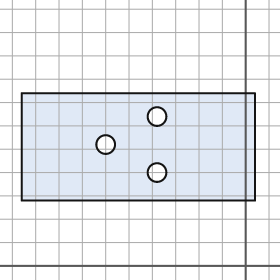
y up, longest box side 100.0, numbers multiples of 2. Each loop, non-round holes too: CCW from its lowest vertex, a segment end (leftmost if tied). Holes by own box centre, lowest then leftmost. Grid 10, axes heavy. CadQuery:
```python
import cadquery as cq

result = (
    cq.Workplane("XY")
    .moveTo(-96.0, 28.0)
    .lineTo(4.0, 28.0)
    .lineTo(4.0, 74.0)
    .lineTo(-96.0, 74.0)
    .close()
    .moveTo(-38.0, 40.0)
    .circle(4.0)
    .moveTo(-60.0, 52.0)
    .circle(4.0)
    .moveTo(-38.0, 64.0)
    .circle(4.0)
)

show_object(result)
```